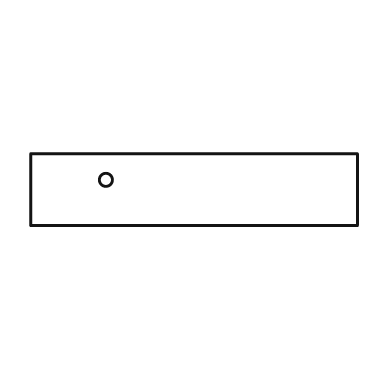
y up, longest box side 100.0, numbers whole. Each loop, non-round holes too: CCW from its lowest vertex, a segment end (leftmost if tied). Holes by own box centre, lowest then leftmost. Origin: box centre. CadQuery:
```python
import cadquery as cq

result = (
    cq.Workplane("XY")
    .moveTo(-50.0, -11.0)
    .lineTo(50.0, -11.0)
    .lineTo(50.0, 11.0)
    .lineTo(-50.0, 11.0)
    .close()
    .moveTo(-27.0, 3.0)
    .circle(2.0)
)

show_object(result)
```